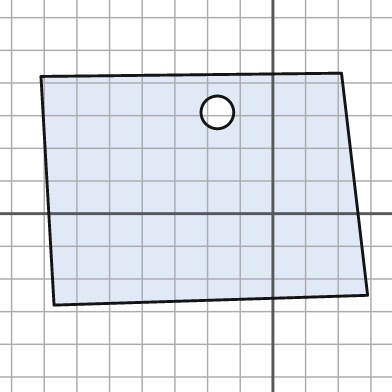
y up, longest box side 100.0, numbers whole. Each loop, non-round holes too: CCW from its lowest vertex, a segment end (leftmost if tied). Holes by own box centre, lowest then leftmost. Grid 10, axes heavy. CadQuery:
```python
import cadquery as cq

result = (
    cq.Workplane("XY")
    .moveTo(-67.0, -28.0)
    .lineTo(29.0, -25.0)
    .lineTo(21.0, 43.0)
    .lineTo(-71.0, 42.0)
    .close()
    .moveTo(-17.0, 31.0)
    .circle(5.0)
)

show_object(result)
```